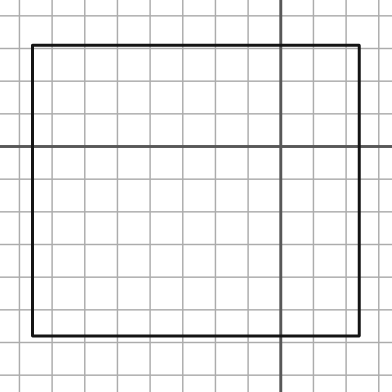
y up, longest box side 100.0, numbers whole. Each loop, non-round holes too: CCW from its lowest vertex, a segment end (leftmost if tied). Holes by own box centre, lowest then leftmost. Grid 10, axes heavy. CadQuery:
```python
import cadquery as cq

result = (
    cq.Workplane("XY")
    .moveTo(-76.0, -58.0)
    .lineTo(24.0, -58.0)
    .lineTo(24.0, 31.0)
    .lineTo(-76.0, 31.0)
    .close()
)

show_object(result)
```